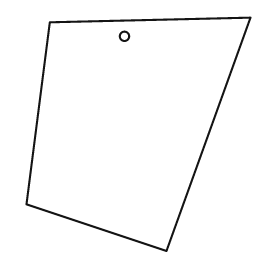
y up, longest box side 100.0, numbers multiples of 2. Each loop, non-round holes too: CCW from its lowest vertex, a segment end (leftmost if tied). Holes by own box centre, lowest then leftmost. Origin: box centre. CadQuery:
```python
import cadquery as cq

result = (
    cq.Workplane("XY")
    .moveTo(12.0, -50.0)
    .lineTo(48.0, 50.0)
    .lineTo(-38.0, 48.0)
    .lineTo(-48.0, -30.0)
    .close()
    .moveTo(-6.0, 42.0)
    .circle(2.0)
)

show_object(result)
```